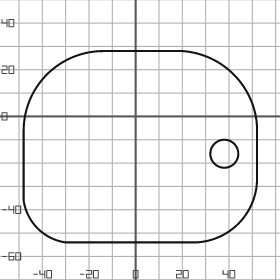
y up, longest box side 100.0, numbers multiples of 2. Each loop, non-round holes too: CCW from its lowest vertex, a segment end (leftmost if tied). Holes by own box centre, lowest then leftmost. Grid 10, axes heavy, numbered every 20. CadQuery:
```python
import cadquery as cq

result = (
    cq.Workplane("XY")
    .moveTo(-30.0, -54.0)
    .lineTo(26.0, -54.0)
    .threePointArc((44.0, -46.0), (52.0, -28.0))
    .lineTo(52.0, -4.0)
    .threePointArc((42.0, 18.0), (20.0, 28.0))
    .lineTo(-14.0, 28.0)
    .threePointArc((-38.0, 18.0), (-48.0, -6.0))
    .lineTo(-48.0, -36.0)
    .threePointArc((-42.0, -48.0), (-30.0, -54.0))
    .close()
    .moveTo(38.0, -16.0)
    .circle(6.0)
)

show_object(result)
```